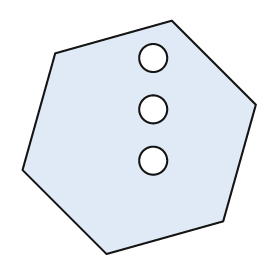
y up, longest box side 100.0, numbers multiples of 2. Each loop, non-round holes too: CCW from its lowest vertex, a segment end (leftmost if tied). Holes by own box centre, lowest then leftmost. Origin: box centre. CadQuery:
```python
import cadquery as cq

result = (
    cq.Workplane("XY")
    .moveTo(-14.0, -50.0)
    .lineTo(36.0, -36.0)
    .lineTo(50.0, 14.0)
    .lineTo(14.0, 50.0)
    .lineTo(-36.0, 36.0)
    .lineTo(-50.0, -14.0)
    .close()
    .moveTo(6.0, -10.0)
    .circle(6.0)
    .moveTo(6.0, 12.0)
    .circle(6.0)
    .moveTo(6.0, 34.0)
    .circle(6.0)
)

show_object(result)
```